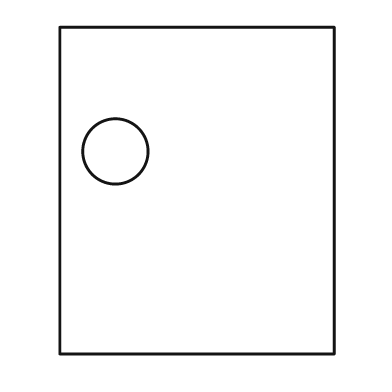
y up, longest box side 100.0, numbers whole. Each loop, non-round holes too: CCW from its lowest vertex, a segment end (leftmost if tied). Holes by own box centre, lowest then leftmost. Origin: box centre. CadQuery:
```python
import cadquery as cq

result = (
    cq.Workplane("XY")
    .moveTo(-42.0, -50.0)
    .lineTo(42.0, -50.0)
    .lineTo(42.0, 50.0)
    .lineTo(-42.0, 50.0)
    .close()
    .moveTo(-25.0, 12.0)
    .circle(10.0)
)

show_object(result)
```